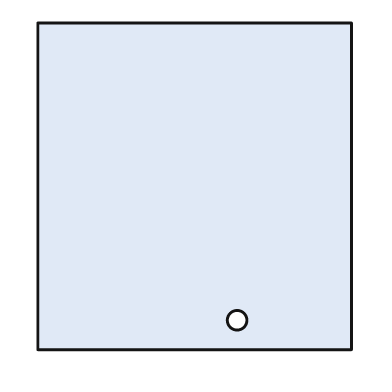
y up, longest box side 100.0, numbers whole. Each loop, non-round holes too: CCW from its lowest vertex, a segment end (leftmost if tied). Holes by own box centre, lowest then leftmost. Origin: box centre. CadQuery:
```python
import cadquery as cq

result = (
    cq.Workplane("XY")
    .moveTo(-48.0, -50.0)
    .lineTo(48.0, -50.0)
    .lineTo(48.0, 50.0)
    .lineTo(-48.0, 50.0)
    .close()
    .moveTo(13.0, -41.0)
    .circle(3.0)
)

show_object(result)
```